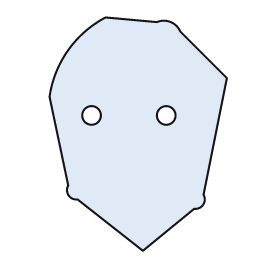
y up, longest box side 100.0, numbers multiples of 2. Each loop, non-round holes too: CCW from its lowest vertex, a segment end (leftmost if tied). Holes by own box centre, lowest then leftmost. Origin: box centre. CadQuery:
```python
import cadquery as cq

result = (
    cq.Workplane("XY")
    .moveTo(2.0, -50.0)
    .lineTo(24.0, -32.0)
    .threePointArc((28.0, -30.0), (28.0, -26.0))
    .lineTo(38.0, 24.0)
    .lineTo(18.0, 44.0)
    .threePointArc((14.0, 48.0), (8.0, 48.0))
    .lineTo(-14.0, 50.0)
    .threePointArc((-30.0, 36.0), (-38.0, 16.0))
    .lineTo(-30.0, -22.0)
    .threePointArc((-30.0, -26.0), (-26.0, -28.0))
    .close()
    .moveTo(-20.0, 8.0)
    .circle(4.0)
    .moveTo(12.0, 8.0)
    .circle(4.0)
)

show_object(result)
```